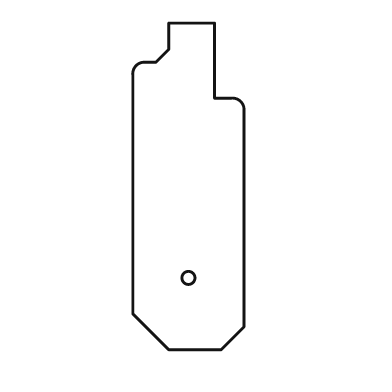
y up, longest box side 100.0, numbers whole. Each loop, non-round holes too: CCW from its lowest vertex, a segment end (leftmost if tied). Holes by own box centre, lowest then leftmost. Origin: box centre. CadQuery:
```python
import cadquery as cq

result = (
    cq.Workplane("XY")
    .moveTo(-6.0, -50.0)
    .lineTo(10.0, -50.0)
    .lineTo(17.0, -43.0)
    .lineTo(17.0, 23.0)
    .threePointArc((16.0, 26.0), (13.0, 27.0))
    .lineTo(8.0, 27.0)
    .lineTo(8.0, 50.0)
    .lineTo(-6.0, 50.0)
    .lineTo(-6.0, 42.0)
    .lineTo(-10.0, 38.0)
    .lineTo(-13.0, 38.0)
    .threePointArc((-16.0, 37.0), (-17.0, 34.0))
    .lineTo(-17.0, -39.0)
    .close()
    .moveTo(0.0, -28.0)
    .circle(2.0)
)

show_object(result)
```